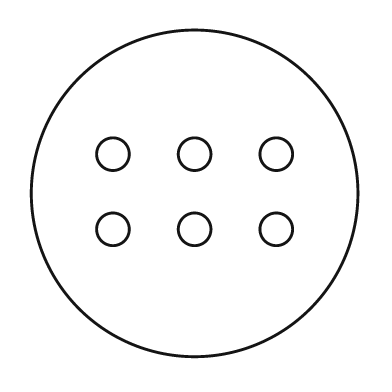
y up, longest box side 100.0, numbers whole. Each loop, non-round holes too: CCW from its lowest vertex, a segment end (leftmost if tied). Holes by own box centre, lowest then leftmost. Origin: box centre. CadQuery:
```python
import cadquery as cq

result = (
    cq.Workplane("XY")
    .moveTo(0.0, 0.0)
    .circle(50.0)
    .moveTo(-25.0, -11.0)
    .circle(5.0)
    .moveTo(0.0, -11.0)
    .circle(5.0)
    .moveTo(25.0, -11.0)
    .circle(5.0)
    .moveTo(-25.0, 12.0)
    .circle(5.0)
    .moveTo(0.0, 12.0)
    .circle(5.0)
    .moveTo(25.0, 12.0)
    .circle(5.0)
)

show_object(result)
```